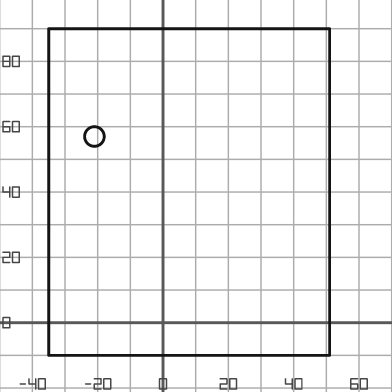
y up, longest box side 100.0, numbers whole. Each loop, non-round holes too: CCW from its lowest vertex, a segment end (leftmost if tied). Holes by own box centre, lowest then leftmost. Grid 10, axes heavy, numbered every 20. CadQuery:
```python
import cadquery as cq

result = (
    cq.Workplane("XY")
    .moveTo(-35.0, -10.0)
    .lineTo(51.0, -10.0)
    .lineTo(51.0, 90.0)
    .lineTo(-35.0, 90.0)
    .close()
    .moveTo(-21.0, 57.0)
    .circle(3.0)
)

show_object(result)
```